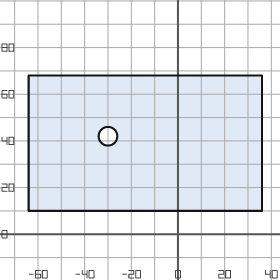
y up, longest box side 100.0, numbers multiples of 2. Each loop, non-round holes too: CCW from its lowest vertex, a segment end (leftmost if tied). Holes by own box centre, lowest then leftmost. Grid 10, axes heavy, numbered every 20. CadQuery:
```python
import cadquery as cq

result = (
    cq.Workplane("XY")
    .moveTo(-64.0, 10.0)
    .lineTo(36.0, 10.0)
    .lineTo(36.0, 68.0)
    .lineTo(-64.0, 68.0)
    .close()
    .moveTo(-30.0, 42.0)
    .circle(4.0)
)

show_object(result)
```